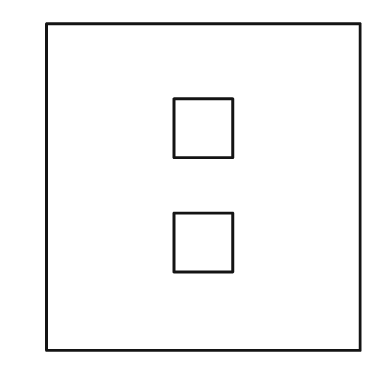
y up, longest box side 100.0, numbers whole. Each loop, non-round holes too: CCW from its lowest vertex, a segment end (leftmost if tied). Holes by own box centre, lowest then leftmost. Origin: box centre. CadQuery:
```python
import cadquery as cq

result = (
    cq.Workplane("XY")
    .moveTo(-48.0, -50.0)
    .lineTo(48.0, -50.0)
    .lineTo(48.0, 50.0)
    .lineTo(-48.0, 50.0)
    .close()
    .moveTo(-9.0, -26.0)
    .lineTo(9.0, -26.0)
    .lineTo(9.0, -8.0)
    .lineTo(-9.0, -8.0)
    .close()
    .moveTo(-9.0, 9.0)
    .lineTo(9.0, 9.0)
    .lineTo(9.0, 27.0)
    .lineTo(-9.0, 27.0)
    .close()
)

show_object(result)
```